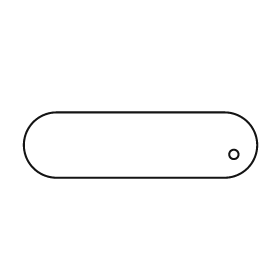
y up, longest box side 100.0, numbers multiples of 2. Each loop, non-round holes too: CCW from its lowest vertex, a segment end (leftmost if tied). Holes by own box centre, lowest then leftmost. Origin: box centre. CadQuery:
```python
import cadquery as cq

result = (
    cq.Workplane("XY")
    .moveTo(-36.0, -14.0)
    .lineTo(36.0, -14.0)
    .threePointArc((50.0, 0.0), (36.0, 14.0))
    .lineTo(-36.0, 14.0)
    .threePointArc((-50.0, 0.0), (-36.0, -14.0))
    .close()
    .moveTo(40.0, -4.0)
    .circle(2.0)
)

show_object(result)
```